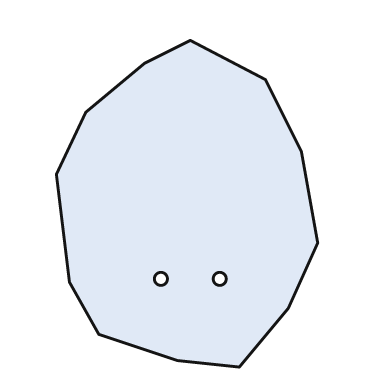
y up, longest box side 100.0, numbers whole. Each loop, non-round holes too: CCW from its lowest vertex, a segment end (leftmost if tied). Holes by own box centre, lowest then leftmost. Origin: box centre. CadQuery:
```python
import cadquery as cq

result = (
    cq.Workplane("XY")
    .moveTo(16.0, -50.0)
    .lineTo(31.0, -32.0)
    .lineTo(40.0, -12.0)
    .lineTo(35.0, 16.0)
    .lineTo(24.0, 38.0)
    .lineTo(1.0, 50.0)
    .lineTo(-13.0, 43.0)
    .lineTo(-31.0, 28.0)
    .lineTo(-40.0, 9.0)
    .lineTo(-36.0, -24.0)
    .lineTo(-27.0, -40.0)
    .lineTo(-3.0, -48.0)
    .close()
    .moveTo(-8.0, -23.0)
    .circle(2.0)
    .moveTo(10.0, -23.0)
    .circle(2.0)
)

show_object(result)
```